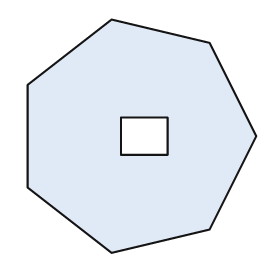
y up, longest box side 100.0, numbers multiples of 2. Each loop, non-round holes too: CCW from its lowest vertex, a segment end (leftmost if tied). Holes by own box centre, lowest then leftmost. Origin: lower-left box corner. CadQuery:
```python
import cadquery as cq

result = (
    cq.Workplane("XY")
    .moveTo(36.0, 0.0)
    .lineTo(78.0, 10.0)
    .lineTo(98.0, 50.0)
    .lineTo(78.0, 90.0)
    .lineTo(36.0, 100.0)
    .lineTo(0.0, 72.0)
    .lineTo(0.0, 28.0)
    .close()
    .moveTo(40.0, 42.0)
    .lineTo(60.0, 42.0)
    .lineTo(60.0, 58.0)
    .lineTo(40.0, 58.0)
    .close()
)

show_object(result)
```